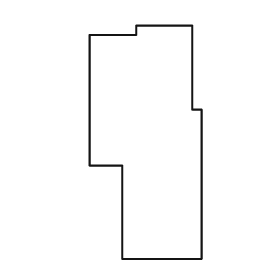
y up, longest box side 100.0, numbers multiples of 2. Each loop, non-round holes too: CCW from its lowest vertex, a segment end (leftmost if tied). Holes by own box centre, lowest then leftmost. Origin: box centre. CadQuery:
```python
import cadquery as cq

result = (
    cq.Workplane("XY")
    .moveTo(-10.0, -50.0)
    .lineTo(24.0, -50.0)
    .lineTo(24.0, 14.0)
    .lineTo(20.0, 14.0)
    .lineTo(20.0, 50.0)
    .lineTo(-4.0, 50.0)
    .lineTo(-4.0, 46.0)
    .lineTo(-24.0, 46.0)
    .lineTo(-24.0, -10.0)
    .lineTo(-10.0, -10.0)
    .close()
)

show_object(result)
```